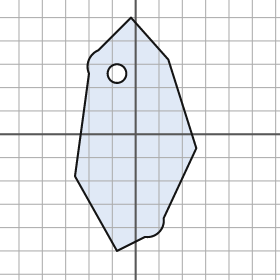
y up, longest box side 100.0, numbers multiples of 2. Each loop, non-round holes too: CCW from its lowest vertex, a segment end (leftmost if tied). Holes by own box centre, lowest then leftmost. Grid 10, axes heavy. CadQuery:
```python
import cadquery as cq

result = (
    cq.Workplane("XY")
    .moveTo(-8.0, -50.0)
    .lineTo(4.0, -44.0)
    .threePointArc((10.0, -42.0), (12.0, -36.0))
    .lineTo(26.0, -6.0)
    .lineTo(14.0, 32.0)
    .lineTo(-2.0, 50.0)
    .lineTo(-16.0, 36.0)
    .threePointArc((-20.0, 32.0), (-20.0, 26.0))
    .lineTo(-26.0, -18.0)
    .close()
    .moveTo(-8.0, 26.0)
    .circle(4.0)
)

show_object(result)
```